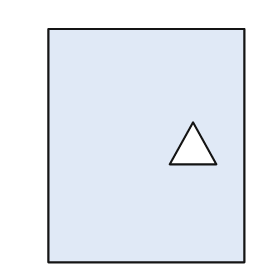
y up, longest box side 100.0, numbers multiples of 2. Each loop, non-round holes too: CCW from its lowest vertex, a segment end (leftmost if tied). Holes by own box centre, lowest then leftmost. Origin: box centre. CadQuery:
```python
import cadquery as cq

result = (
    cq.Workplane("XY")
    .moveTo(-42.0, -50.0)
    .lineTo(42.0, -50.0)
    .lineTo(42.0, 50.0)
    .lineTo(-42.0, 50.0)
    .close()
    .moveTo(10.0, -8.0)
    .lineTo(30.0, -8.0)
    .lineTo(20.0, 10.0)
    .close()
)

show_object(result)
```